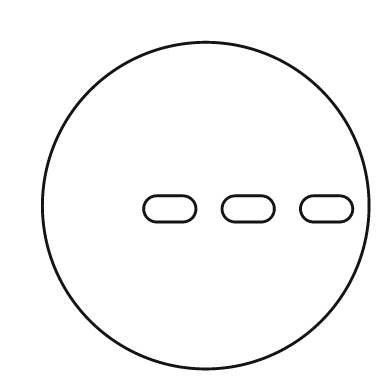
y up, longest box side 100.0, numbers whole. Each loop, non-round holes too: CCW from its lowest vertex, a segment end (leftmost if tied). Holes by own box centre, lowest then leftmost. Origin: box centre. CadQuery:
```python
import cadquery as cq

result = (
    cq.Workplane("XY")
    .moveTo(0.0, 0.0)
    .circle(50.0)
    .moveTo(-15.0, -5.0)
    .lineTo(-7.0, -5.0)
    .threePointArc((-3.0, -1.0), (-7.0, 3.0))
    .lineTo(-15.0, 3.0)
    .threePointArc((-19.0, -1.0), (-15.0, -5.0))
    .close()
    .moveTo(9.0, -5.0)
    .lineTo(17.0, -5.0)
    .threePointArc((21.0, -1.0), (17.0, 3.0))
    .lineTo(9.0, 3.0)
    .threePointArc((5.0, -1.0), (9.0, -5.0))
    .close()
    .moveTo(33.0, -5.0)
    .lineTo(41.0, -5.0)
    .threePointArc((45.0, -1.0), (41.0, 3.0))
    .lineTo(33.0, 3.0)
    .threePointArc((29.0, -1.0), (33.0, -5.0))
    .close()
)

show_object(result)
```